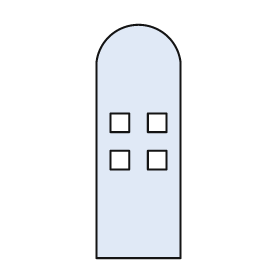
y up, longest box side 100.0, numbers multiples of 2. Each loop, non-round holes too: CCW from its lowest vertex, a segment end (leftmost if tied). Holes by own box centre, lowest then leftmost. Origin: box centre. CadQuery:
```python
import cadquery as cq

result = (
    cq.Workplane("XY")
    .moveTo(-18.0, -50.0)
    .lineTo(18.0, -50.0)
    .lineTo(18.0, 34.0)
    .threePointArc((0.0, 50.0), (-18.0, 34.0))
    .close()
    .moveTo(-12.0, -12.0)
    .lineTo(-4.0, -12.0)
    .lineTo(-4.0, -4.0)
    .lineTo(-12.0, -4.0)
    .close()
    .moveTo(4.0, -12.0)
    .lineTo(12.0, -12.0)
    .lineTo(12.0, -4.0)
    .lineTo(4.0, -4.0)
    .close()
    .moveTo(-12.0, 4.0)
    .lineTo(-4.0, 4.0)
    .lineTo(-4.0, 12.0)
    .lineTo(-12.0, 12.0)
    .close()
    .moveTo(4.0, 4.0)
    .lineTo(12.0, 4.0)
    .lineTo(12.0, 12.0)
    .lineTo(4.0, 12.0)
    .close()
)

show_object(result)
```